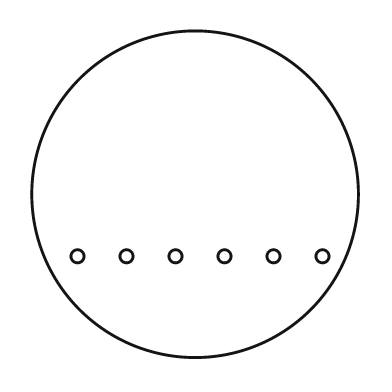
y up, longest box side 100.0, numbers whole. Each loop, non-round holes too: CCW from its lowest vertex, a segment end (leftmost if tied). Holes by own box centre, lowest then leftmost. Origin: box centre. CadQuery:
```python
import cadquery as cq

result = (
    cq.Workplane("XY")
    .moveTo(0.0, 0.0)
    .circle(50.0)
    .moveTo(-36.0, -19.0)
    .circle(2.0)
    .moveTo(-21.0, -19.0)
    .circle(2.0)
    .moveTo(-6.0, -19.0)
    .circle(2.0)
    .moveTo(9.0, -19.0)
    .circle(2.0)
    .moveTo(24.0, -19.0)
    .circle(2.0)
    .moveTo(39.0, -19.0)
    .circle(2.0)
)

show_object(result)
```